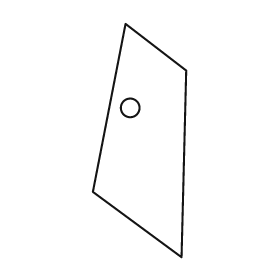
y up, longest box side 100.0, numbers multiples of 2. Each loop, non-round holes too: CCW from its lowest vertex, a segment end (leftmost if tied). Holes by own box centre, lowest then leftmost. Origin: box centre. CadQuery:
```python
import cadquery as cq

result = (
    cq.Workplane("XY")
    .moveTo(18.0, -50.0)
    .lineTo(20.0, 30.0)
    .lineTo(-6.0, 50.0)
    .lineTo(-20.0, -22.0)
    .close()
    .moveTo(-4.0, 14.0)
    .circle(4.0)
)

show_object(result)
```